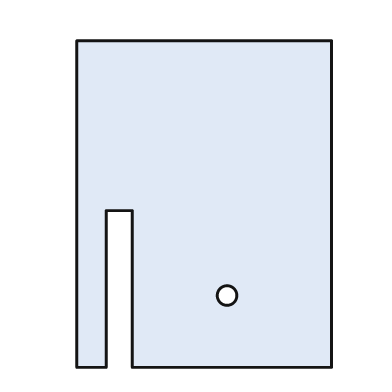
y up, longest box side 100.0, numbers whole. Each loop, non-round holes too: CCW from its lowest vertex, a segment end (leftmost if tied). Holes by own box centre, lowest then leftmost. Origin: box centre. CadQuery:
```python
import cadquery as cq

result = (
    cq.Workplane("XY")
    .moveTo(-39.0, -50.0)
    .lineTo(-30.0, -50.0)
    .lineTo(-30.0, -2.0)
    .lineTo(-22.0, -2.0)
    .lineTo(-22.0, -50.0)
    .lineTo(39.0, -50.0)
    .lineTo(39.0, 50.0)
    .lineTo(-39.0, 50.0)
    .close()
    .moveTo(7.0, -28.0)
    .circle(3.0)
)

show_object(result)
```